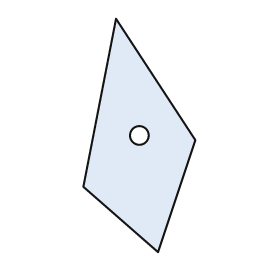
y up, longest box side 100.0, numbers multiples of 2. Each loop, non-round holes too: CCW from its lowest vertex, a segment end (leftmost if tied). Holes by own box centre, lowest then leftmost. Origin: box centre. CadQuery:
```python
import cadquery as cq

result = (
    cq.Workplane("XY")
    .moveTo(8.0, -50.0)
    .lineTo(24.0, -2.0)
    .lineTo(-10.0, 50.0)
    .lineTo(-24.0, -22.0)
    .close()
    .moveTo(0.0, 0.0)
    .circle(4.0)
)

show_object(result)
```